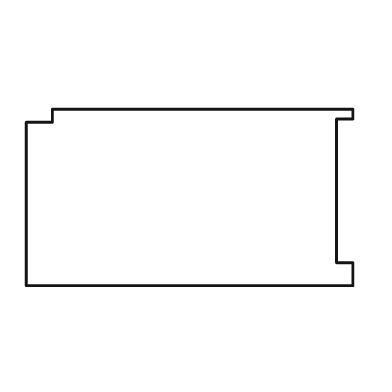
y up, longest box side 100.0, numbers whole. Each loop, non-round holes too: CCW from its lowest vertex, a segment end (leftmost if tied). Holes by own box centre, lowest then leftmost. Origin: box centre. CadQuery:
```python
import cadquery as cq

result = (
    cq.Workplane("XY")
    .moveTo(-50.0, -27.0)
    .lineTo(50.0, -27.0)
    .lineTo(50.0, -20.0)
    .lineTo(45.0, -20.0)
    .lineTo(45.0, 24.0)
    .lineTo(50.0, 24.0)
    .lineTo(50.0, 27.0)
    .lineTo(-42.0, 27.0)
    .lineTo(-42.0, 23.0)
    .lineTo(-50.0, 23.0)
    .close()
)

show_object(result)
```